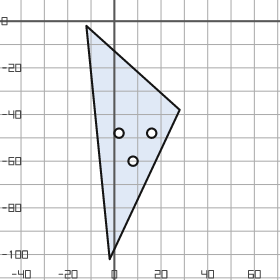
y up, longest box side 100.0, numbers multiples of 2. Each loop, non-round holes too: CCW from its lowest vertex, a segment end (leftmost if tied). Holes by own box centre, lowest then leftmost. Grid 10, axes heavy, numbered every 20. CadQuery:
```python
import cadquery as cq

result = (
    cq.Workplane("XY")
    .moveTo(-2.0, -102.0)
    .lineTo(28.0, -38.0)
    .lineTo(-12.0, -2.0)
    .close()
    .moveTo(8.0, -60.0)
    .circle(2.0)
    .moveTo(2.0, -48.0)
    .circle(2.0)
    .moveTo(16.0, -48.0)
    .circle(2.0)
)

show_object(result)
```